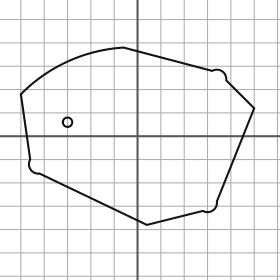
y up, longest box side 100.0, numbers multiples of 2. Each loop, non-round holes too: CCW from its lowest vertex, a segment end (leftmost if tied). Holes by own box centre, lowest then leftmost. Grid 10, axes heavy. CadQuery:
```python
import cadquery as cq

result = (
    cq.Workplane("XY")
    .moveTo(4.0, -38.0)
    .lineTo(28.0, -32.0)
    .threePointArc((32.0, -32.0), (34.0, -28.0))
    .lineTo(50.0, 12.0)
    .lineTo(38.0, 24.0)
    .threePointArc((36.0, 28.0), (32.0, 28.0))
    .lineTo(-6.0, 38.0)
    .threePointArc((-30.0, 32.0), (-50.0, 18.0))
    .lineTo(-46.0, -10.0)
    .threePointArc((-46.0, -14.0), (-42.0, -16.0))
    .close()
    .moveTo(-30.0, 6.0)
    .circle(2.0)
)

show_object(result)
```